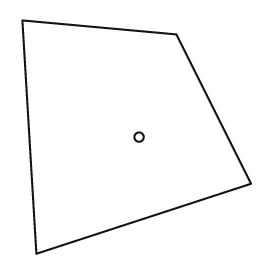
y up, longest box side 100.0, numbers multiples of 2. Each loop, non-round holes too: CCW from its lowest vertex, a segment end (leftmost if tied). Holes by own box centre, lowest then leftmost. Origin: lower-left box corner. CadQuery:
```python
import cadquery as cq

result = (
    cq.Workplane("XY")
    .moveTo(6.0, 0.0)
    .lineTo(98.0, 30.0)
    .lineTo(66.0, 94.0)
    .lineTo(0.0, 100.0)
    .close()
    .moveTo(50.0, 50.0)
    .circle(2.0)
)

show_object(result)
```